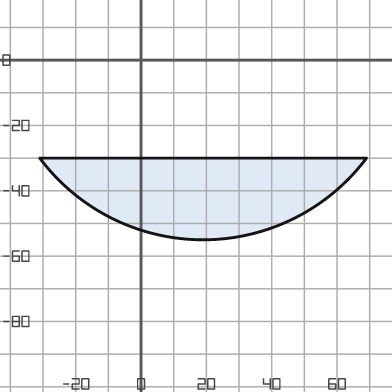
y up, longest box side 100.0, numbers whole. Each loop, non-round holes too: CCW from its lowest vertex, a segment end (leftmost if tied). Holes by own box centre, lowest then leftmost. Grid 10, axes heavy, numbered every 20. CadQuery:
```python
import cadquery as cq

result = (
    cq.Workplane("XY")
    .moveTo(-31.0, -30.0)
    .threePointArc((19.0, -55.0), (69.0, -30.0))
    .close()
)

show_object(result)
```